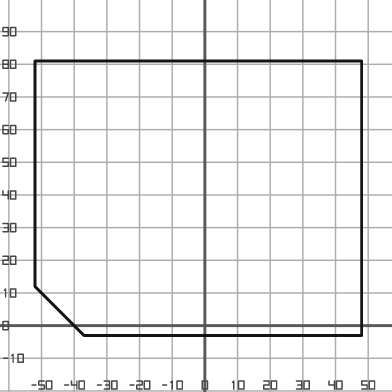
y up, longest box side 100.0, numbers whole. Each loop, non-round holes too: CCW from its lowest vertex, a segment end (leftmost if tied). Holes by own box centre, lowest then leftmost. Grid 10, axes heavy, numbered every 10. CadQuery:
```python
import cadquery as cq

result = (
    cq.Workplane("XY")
    .moveTo(-37.0, -3.0)
    .lineTo(48.0, -3.0)
    .lineTo(48.0, 81.0)
    .lineTo(-52.0, 81.0)
    .lineTo(-52.0, 12.0)
    .close()
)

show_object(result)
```